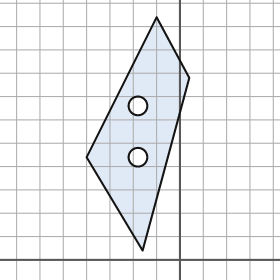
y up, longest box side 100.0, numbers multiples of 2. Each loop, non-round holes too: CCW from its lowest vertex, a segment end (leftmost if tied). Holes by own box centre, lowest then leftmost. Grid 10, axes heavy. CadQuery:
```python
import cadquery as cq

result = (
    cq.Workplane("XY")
    .moveTo(-16.0, 4.0)
    .lineTo(4.0, 78.0)
    .lineTo(-10.0, 104.0)
    .lineTo(-40.0, 44.0)
    .close()
    .moveTo(-18.0, 44.0)
    .circle(4.0)
    .moveTo(-18.0, 66.0)
    .circle(4.0)
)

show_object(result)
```